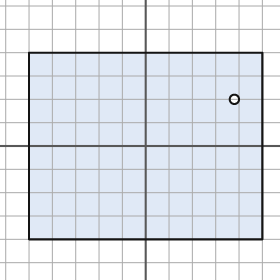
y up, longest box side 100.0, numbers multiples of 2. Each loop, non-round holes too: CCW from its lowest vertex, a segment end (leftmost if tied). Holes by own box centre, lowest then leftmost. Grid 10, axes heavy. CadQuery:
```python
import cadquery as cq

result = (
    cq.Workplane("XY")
    .moveTo(-50.0, -40.0)
    .lineTo(50.0, -40.0)
    .lineTo(50.0, 40.0)
    .lineTo(-50.0, 40.0)
    .close()
    .moveTo(38.0, 20.0)
    .circle(2.0)
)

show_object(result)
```